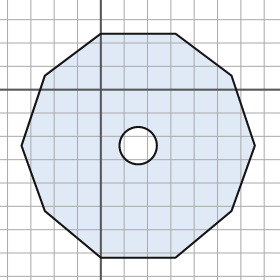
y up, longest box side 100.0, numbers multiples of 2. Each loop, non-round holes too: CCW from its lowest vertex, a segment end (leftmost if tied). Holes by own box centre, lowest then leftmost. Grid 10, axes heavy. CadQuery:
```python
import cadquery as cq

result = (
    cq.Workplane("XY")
    .moveTo(0.0, -72.0)
    .lineTo(32.0, -72.0)
    .lineTo(56.0, -52.0)
    .lineTo(66.0, -24.0)
    .lineTo(56.0, 6.0)
    .lineTo(32.0, 24.0)
    .lineTo(0.0, 24.0)
    .lineTo(-24.0, 6.0)
    .lineTo(-34.0, -24.0)
    .lineTo(-24.0, -52.0)
    .close()
    .moveTo(16.0, -24.0)
    .circle(8.0)
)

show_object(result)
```